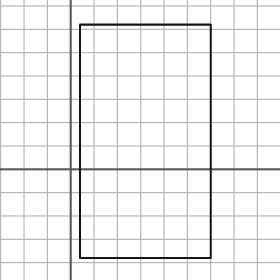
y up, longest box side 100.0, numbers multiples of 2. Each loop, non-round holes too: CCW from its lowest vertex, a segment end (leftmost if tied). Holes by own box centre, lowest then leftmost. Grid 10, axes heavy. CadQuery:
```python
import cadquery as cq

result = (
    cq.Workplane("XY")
    .moveTo(4.0, -38.0)
    .lineTo(60.0, -38.0)
    .lineTo(60.0, 62.0)
    .lineTo(4.0, 62.0)
    .close()
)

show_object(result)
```